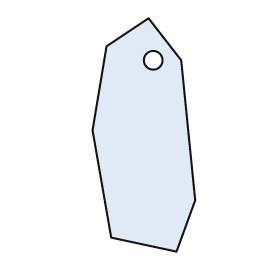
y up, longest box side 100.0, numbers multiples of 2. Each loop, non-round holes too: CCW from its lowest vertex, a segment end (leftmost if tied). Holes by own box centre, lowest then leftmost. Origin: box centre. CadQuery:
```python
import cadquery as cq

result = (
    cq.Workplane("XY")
    .moveTo(14.0, -50.0)
    .lineTo(22.0, -28.0)
    .lineTo(16.0, 32.0)
    .lineTo(2.0, 50.0)
    .lineTo(-16.0, 38.0)
    .lineTo(-22.0, 2.0)
    .lineTo(-14.0, -44.0)
    .close()
    .moveTo(4.0, 32.0)
    .circle(4.0)
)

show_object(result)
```